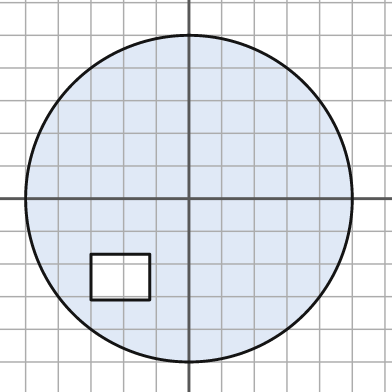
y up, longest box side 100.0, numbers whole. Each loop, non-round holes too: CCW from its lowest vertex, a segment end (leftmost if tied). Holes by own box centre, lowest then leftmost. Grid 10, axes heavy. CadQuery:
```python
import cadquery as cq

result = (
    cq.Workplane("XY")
    .moveTo(0.0, 0.0)
    .circle(50.0)
    .moveTo(-30.0, -31.0)
    .lineTo(-12.0, -31.0)
    .lineTo(-12.0, -17.0)
    .lineTo(-30.0, -17.0)
    .close()
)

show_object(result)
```